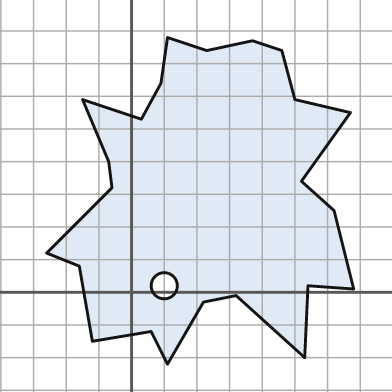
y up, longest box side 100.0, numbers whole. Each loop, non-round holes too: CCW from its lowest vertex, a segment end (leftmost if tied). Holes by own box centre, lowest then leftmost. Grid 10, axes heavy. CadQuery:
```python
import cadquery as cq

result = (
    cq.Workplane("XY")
    .moveTo(11.0, -22.0)
    .lineTo(22.0, -3.0)
    .lineTo(32.0, -1.0)
    .lineTo(53.0, -20.0)
    .lineTo(54.0, 2.0)
    .lineTo(68.0, 1.0)
    .lineTo(62.0, 25.0)
    .lineTo(52.0, 34.0)
    .lineTo(67.0, 55.0)
    .lineTo(50.0, 59.0)
    .lineTo(46.0, 74.0)
    .lineTo(37.0, 77.0)
    .lineTo(23.0, 74.0)
    .lineTo(11.0, 78.0)
    .lineTo(9.0, 64.0)
    .lineTo(3.0, 53.0)
    .lineTo(-15.0, 59.0)
    .lineTo(-7.0, 40.0)
    .lineTo(-6.0, 32.0)
    .lineTo(-26.0, 12.0)
    .lineTo(-16.0, 8.0)
    .lineTo(-12.0, -15.0)
    .lineTo(6.0, -12.0)
    .close()
    .moveTo(10.0, 2.0)
    .circle(4.0)
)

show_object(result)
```